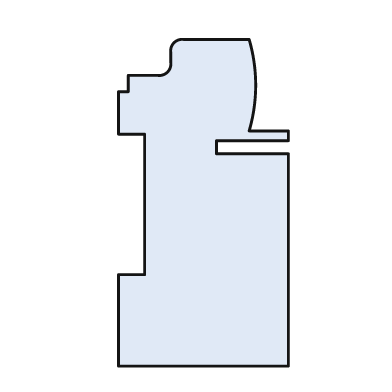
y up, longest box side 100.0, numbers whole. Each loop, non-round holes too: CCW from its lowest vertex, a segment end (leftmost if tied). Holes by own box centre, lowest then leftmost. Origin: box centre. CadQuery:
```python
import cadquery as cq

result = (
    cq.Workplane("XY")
    .moveTo(-26.0, -50.0)
    .lineTo(26.0, -50.0)
    .lineTo(26.0, 15.0)
    .lineTo(4.0, 15.0)
    .lineTo(4.0, 19.0)
    .lineTo(26.0, 19.0)
    .lineTo(26.0, 22.0)
    .lineTo(14.0, 22.0)
    .threePointArc((16.0, 36.0), (14.0, 50.0))
    .lineTo(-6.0, 50.0)
    .threePointArc((-9.0, 49.0), (-10.0, 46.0))
    .lineTo(-10.0, 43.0)
    .threePointArc((-11.0, 40.0), (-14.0, 39.0))
    .lineTo(-23.0, 39.0)
    .lineTo(-23.0, 34.0)
    .lineTo(-26.0, 34.0)
    .lineTo(-26.0, 21.0)
    .lineTo(-18.0, 21.0)
    .lineTo(-18.0, -22.0)
    .lineTo(-26.0, -22.0)
    .close()
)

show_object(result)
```